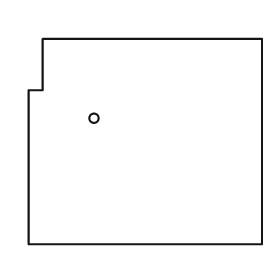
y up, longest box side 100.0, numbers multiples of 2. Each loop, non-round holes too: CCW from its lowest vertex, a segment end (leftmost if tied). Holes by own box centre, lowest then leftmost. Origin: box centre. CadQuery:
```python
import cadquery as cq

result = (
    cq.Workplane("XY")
    .moveTo(-50.0, -44.0)
    .lineTo(50.0, -44.0)
    .lineTo(50.0, 44.0)
    .lineTo(-44.0, 44.0)
    .lineTo(-44.0, 22.0)
    .lineTo(-50.0, 22.0)
    .close()
    .moveTo(-22.0, 10.0)
    .circle(2.0)
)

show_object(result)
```